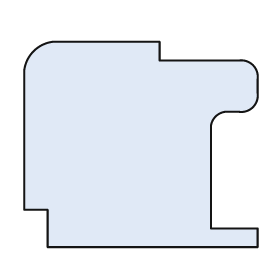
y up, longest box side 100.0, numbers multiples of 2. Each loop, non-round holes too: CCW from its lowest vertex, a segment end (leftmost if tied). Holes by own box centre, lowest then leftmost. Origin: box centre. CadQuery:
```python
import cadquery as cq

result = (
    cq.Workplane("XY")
    .moveTo(-40.0, -44.0)
    .lineTo(50.0, -44.0)
    .lineTo(50.0, -36.0)
    .lineTo(30.0, -36.0)
    .lineTo(30.0, 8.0)
    .threePointArc((32.0, 12.0), (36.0, 14.0))
    .lineTo(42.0, 14.0)
    .threePointArc((48.0, 16.0), (50.0, 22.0))
    .lineTo(50.0, 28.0)
    .threePointArc((48.0, 34.0), (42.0, 36.0))
    .lineTo(8.0, 36.0)
    .lineTo(8.0, 44.0)
    .lineTo(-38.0, 44.0)
    .threePointArc((-46.0, 40.0), (-50.0, 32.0))
    .lineTo(-50.0, -28.0)
    .lineTo(-40.0, -28.0)
    .close()
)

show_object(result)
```